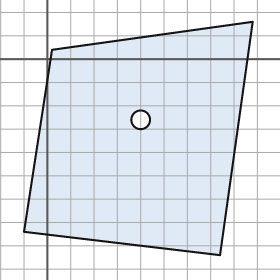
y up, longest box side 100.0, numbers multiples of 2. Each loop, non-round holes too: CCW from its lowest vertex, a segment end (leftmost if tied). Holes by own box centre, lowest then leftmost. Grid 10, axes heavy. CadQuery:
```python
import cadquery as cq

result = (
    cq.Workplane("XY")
    .moveTo(74.0, -84.0)
    .lineTo(88.0, 16.0)
    .lineTo(2.0, 4.0)
    .lineTo(-10.0, -74.0)
    .close()
    .moveTo(40.0, -26.0)
    .circle(4.0)
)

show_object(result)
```